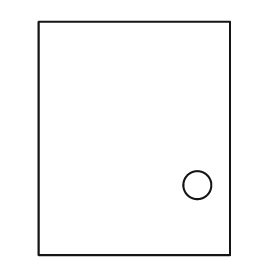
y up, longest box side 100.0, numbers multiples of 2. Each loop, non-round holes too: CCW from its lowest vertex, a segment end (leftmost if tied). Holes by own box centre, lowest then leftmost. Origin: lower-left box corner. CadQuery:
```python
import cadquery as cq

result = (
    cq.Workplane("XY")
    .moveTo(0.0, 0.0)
    .lineTo(82.0, 0.0)
    .lineTo(82.0, 100.0)
    .lineTo(0.0, 100.0)
    .close()
    .moveTo(68.0, 30.0)
    .circle(6.0)
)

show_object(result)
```